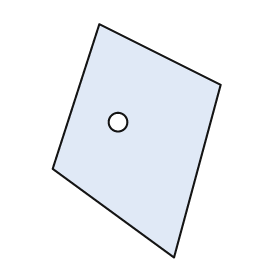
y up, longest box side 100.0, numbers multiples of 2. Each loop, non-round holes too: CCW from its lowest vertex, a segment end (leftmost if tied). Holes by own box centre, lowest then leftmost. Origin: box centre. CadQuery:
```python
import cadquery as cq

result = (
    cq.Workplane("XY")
    .moveTo(16.0, -50.0)
    .lineTo(36.0, 24.0)
    .lineTo(-16.0, 50.0)
    .lineTo(-36.0, -12.0)
    .close()
    .moveTo(-8.0, 8.0)
    .circle(4.0)
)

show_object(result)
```